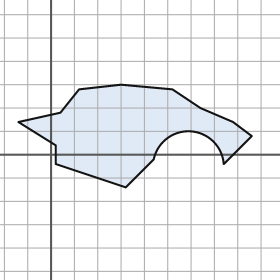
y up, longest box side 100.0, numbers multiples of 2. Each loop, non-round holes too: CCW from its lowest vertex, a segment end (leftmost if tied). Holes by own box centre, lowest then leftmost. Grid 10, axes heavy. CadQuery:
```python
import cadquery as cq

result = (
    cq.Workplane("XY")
    .moveTo(32.0, -14.0)
    .lineTo(44.0, -2.0)
    .threePointArc((60.0, 10.0), (74.0, -4.0))
    .lineTo(86.0, 8.0)
    .lineTo(78.0, 14.0)
    .lineTo(64.0, 20.0)
    .lineTo(52.0, 28.0)
    .lineTo(30.0, 30.0)
    .lineTo(12.0, 28.0)
    .lineTo(4.0, 18.0)
    .lineTo(-14.0, 14.0)
    .lineTo(2.0, 4.0)
    .lineTo(2.0, -4.0)
    .close()
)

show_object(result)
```